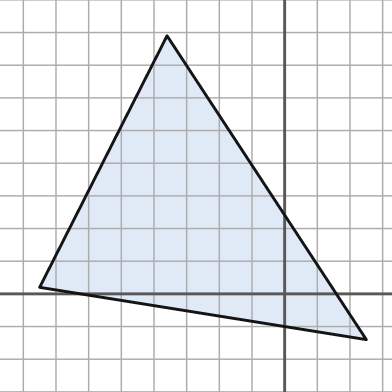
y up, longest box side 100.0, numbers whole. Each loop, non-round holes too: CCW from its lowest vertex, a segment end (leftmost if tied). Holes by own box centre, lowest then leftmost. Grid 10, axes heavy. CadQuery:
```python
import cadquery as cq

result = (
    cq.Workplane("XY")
    .moveTo(25.0, -14.0)
    .lineTo(-36.0, 79.0)
    .lineTo(-75.0, 2.0)
    .close()
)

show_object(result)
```